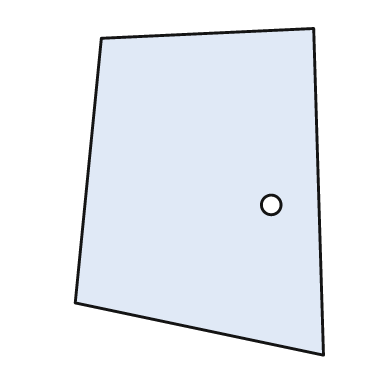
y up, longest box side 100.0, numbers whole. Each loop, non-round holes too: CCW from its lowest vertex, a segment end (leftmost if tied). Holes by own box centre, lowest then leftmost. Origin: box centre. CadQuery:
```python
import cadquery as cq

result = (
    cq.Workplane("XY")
    .moveTo(38.0, -50.0)
    .lineTo(35.0, 50.0)
    .lineTo(-30.0, 47.0)
    .lineTo(-38.0, -34.0)
    .close()
    .moveTo(22.0, -4.0)
    .circle(3.0)
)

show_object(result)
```